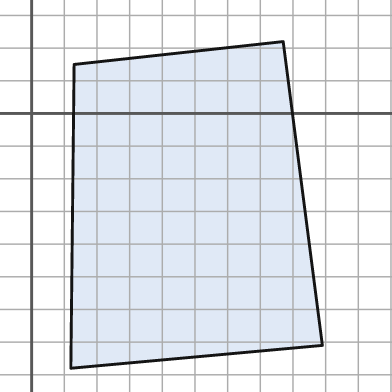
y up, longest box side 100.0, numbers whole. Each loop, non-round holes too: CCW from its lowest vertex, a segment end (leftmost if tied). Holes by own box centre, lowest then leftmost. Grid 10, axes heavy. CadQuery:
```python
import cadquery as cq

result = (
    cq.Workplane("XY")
    .moveTo(12.0, -78.0)
    .lineTo(89.0, -71.0)
    .lineTo(77.0, 22.0)
    .lineTo(13.0, 15.0)
    .close()
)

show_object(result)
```